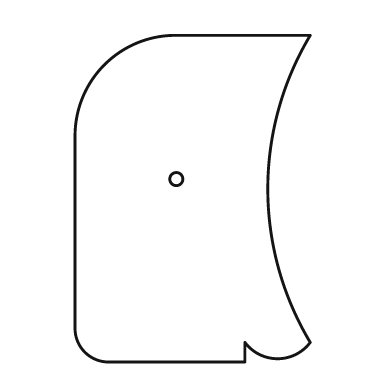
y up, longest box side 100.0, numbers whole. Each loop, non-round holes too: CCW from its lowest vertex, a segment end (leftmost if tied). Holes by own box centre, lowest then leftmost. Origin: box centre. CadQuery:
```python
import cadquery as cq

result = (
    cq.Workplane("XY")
    .moveTo(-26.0, -50.0)
    .lineTo(16.0, -50.0)
    .lineTo(16.0, -44.0)
    .threePointArc((26.0, -49.0), (36.0, -44.0))
    .threePointArc((23.0, 3.0), (36.0, 50.0))
    .lineTo(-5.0, 50.0)
    .threePointArc((-27.0, 41.0), (-36.0, 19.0))
    .lineTo(-36.0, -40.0)
    .threePointArc((-33.0, -47.0), (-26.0, -50.0))
    .close()
    .moveTo(-5.0, 6.0)
    .circle(2.0)
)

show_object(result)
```